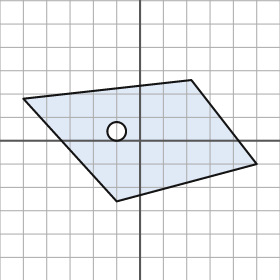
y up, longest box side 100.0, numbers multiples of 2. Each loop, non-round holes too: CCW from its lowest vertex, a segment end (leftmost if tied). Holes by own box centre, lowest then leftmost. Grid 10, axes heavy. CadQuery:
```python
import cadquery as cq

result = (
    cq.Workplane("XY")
    .moveTo(-10.0, -26.0)
    .lineTo(50.0, -10.0)
    .lineTo(22.0, 26.0)
    .lineTo(-50.0, 18.0)
    .close()
    .moveTo(-10.0, 4.0)
    .circle(4.0)
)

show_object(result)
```